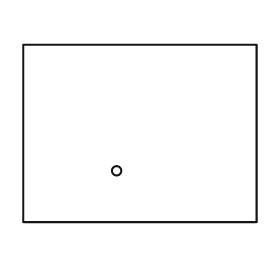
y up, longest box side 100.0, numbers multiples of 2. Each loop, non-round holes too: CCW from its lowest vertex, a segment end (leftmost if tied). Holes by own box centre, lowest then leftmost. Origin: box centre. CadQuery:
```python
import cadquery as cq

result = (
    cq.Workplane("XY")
    .moveTo(-50.0, -38.0)
    .lineTo(50.0, -38.0)
    .lineTo(50.0, 38.0)
    .lineTo(-50.0, 38.0)
    .close()
    .moveTo(-10.0, -16.0)
    .circle(2.0)
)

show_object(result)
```